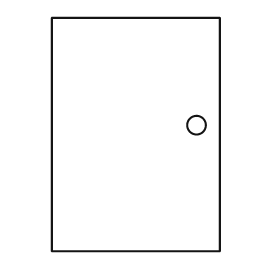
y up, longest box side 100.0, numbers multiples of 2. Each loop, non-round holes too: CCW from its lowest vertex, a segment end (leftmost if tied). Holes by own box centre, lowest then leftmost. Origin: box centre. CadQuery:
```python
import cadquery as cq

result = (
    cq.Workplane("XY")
    .moveTo(-36.0, -50.0)
    .lineTo(36.0, -50.0)
    .lineTo(36.0, 50.0)
    .lineTo(-36.0, 50.0)
    .close()
    .moveTo(26.0, 4.0)
    .circle(4.0)
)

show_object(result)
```